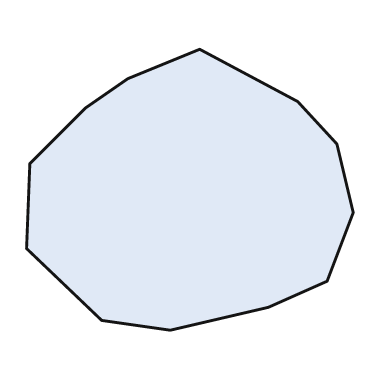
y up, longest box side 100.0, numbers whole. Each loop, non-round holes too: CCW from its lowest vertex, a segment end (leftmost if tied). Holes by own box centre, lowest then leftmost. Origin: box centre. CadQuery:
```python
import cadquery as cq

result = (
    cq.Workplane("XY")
    .moveTo(-6.0, -43.0)
    .lineTo(24.0, -36.0)
    .lineTo(42.0, -28.0)
    .lineTo(50.0, -7.0)
    .lineTo(45.0, 14.0)
    .lineTo(33.0, 27.0)
    .lineTo(3.0, 43.0)
    .lineTo(-19.0, 34.0)
    .lineTo(-32.0, 25.0)
    .lineTo(-49.0, 8.0)
    .lineTo(-50.0, -18.0)
    .lineTo(-27.0, -40.0)
    .close()
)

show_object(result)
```